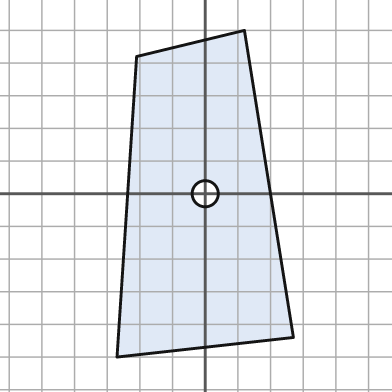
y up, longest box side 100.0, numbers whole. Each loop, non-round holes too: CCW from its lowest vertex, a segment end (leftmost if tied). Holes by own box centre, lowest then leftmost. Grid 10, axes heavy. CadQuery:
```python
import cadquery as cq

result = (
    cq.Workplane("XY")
    .moveTo(-27.0, -50.0)
    .lineTo(27.0, -44.0)
    .lineTo(12.0, 50.0)
    .lineTo(-21.0, 42.0)
    .close()
    .moveTo(0.0, 0.0)
    .circle(4.0)
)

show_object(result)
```